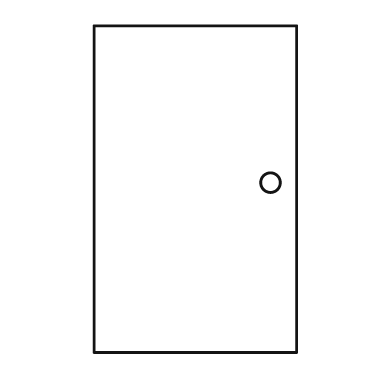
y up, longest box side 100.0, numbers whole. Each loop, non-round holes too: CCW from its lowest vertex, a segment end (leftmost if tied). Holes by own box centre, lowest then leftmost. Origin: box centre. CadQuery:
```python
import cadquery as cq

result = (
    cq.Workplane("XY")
    .moveTo(-31.0, -50.0)
    .lineTo(31.0, -50.0)
    .lineTo(31.0, 50.0)
    .lineTo(-31.0, 50.0)
    .close()
    .moveTo(23.0, 2.0)
    .circle(3.0)
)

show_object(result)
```